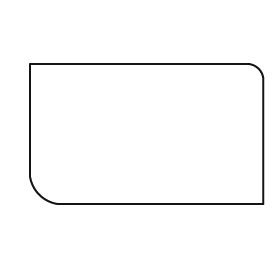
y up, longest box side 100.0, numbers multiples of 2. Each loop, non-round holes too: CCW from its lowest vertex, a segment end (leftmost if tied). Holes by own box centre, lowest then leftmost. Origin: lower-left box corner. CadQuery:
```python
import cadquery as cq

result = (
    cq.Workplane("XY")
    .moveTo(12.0, 0.0)
    .lineTo(100.0, 0.0)
    .lineTo(100.0, 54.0)
    .threePointArc((98.0, 58.0), (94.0, 60.0))
    .lineTo(0.0, 60.0)
    .lineTo(0.0, 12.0)
    .threePointArc((4.0, 4.0), (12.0, 0.0))
    .close()
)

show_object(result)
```